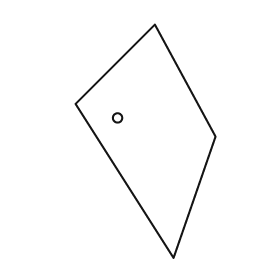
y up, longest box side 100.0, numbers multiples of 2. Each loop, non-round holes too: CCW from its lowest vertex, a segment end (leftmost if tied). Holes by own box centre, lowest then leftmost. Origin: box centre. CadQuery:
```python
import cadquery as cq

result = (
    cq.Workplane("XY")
    .moveTo(12.0, -50.0)
    .lineTo(30.0, 2.0)
    .lineTo(4.0, 50.0)
    .lineTo(-30.0, 16.0)
    .close()
    .moveTo(-12.0, 10.0)
    .circle(2.0)
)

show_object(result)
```